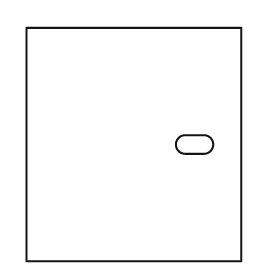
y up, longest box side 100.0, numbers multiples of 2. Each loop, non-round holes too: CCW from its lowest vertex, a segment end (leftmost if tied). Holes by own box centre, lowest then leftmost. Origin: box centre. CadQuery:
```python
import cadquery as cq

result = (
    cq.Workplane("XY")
    .moveTo(-46.0, -50.0)
    .lineTo(46.0, -50.0)
    .lineTo(46.0, 50.0)
    .lineTo(-46.0, 50.0)
    .close()
    .moveTo(22.0, -4.0)
    .lineTo(30.0, -4.0)
    .threePointArc((34.0, 0.0), (30.0, 4.0))
    .lineTo(22.0, 4.0)
    .threePointArc((18.0, 0.0), (22.0, -4.0))
    .close()
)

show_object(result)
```